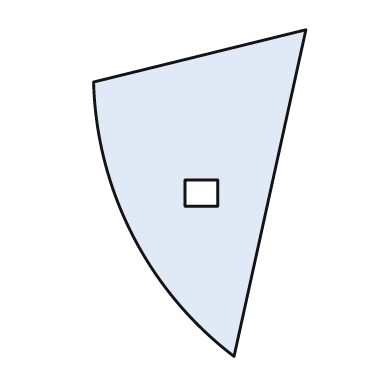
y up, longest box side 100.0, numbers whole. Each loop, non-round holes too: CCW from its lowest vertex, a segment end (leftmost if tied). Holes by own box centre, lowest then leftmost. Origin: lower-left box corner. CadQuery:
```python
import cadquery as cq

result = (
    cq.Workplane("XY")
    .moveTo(43.0, 0.0)
    .lineTo(65.0, 100.0)
    .lineTo(0.0, 84.0)
    .threePointArc((12.0, 37.0), (43.0, 0.0))
    .close()
    .moveTo(28.0, 46.0)
    .lineTo(38.0, 46.0)
    .lineTo(38.0, 54.0)
    .lineTo(28.0, 54.0)
    .close()
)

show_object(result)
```